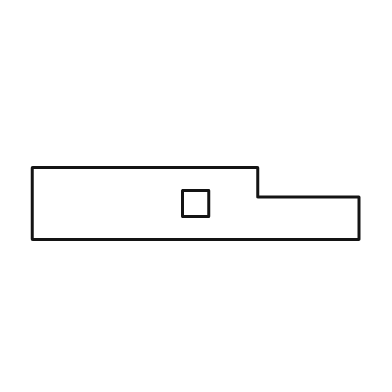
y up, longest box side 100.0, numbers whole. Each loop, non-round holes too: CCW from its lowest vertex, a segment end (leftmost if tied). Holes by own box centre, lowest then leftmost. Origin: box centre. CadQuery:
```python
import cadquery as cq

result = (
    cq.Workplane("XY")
    .moveTo(-50.0, -11.0)
    .lineTo(50.0, -11.0)
    .lineTo(50.0, 2.0)
    .lineTo(19.0, 2.0)
    .lineTo(19.0, 11.0)
    .lineTo(-50.0, 11.0)
    .close()
    .moveTo(-4.0, -4.0)
    .lineTo(4.0, -4.0)
    .lineTo(4.0, 4.0)
    .lineTo(-4.0, 4.0)
    .close()
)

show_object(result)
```